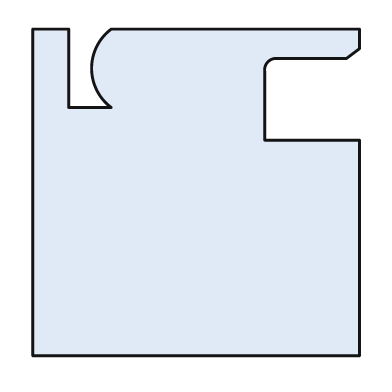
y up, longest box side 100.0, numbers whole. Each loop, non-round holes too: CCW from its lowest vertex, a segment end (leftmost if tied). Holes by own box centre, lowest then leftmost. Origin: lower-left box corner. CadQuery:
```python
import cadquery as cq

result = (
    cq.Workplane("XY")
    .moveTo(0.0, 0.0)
    .lineTo(100.0, 0.0)
    .lineTo(100.0, 66.0)
    .lineTo(71.0, 66.0)
    .lineTo(71.0, 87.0)
    .threePointArc((72.0, 90.0), (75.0, 91.0))
    .lineTo(96.0, 91.0)
    .lineTo(100.0, 94.0)
    .lineTo(100.0, 100.0)
    .lineTo(24.0, 100.0)
    .threePointArc((18.0, 88.0), (24.0, 76.0))
    .lineTo(11.0, 76.0)
    .lineTo(11.0, 100.0)
    .lineTo(0.0, 100.0)
    .close()
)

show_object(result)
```